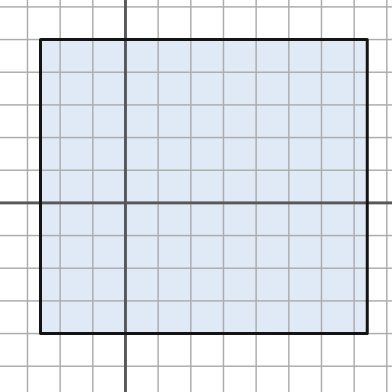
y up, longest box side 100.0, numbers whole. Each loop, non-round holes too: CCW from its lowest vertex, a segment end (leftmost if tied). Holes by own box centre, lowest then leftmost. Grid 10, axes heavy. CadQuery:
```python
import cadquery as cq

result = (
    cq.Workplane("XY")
    .moveTo(-26.0, -40.0)
    .lineTo(74.0, -40.0)
    .lineTo(74.0, 50.0)
    .lineTo(-26.0, 50.0)
    .close()
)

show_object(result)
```